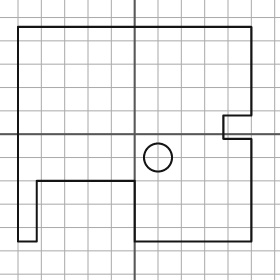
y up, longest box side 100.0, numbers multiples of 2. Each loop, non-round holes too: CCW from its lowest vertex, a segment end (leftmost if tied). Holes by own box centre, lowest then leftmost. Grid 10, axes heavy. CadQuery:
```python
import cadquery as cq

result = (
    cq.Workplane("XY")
    .moveTo(-50.0, -46.0)
    .lineTo(-42.0, -46.0)
    .lineTo(-42.0, -20.0)
    .lineTo(0.0, -20.0)
    .lineTo(0.0, -46.0)
    .lineTo(50.0, -46.0)
    .lineTo(50.0, -2.0)
    .lineTo(38.0, -2.0)
    .lineTo(38.0, 8.0)
    .lineTo(50.0, 8.0)
    .lineTo(50.0, 46.0)
    .lineTo(-50.0, 46.0)
    .close()
    .moveTo(10.0, -10.0)
    .circle(6.0)
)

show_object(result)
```